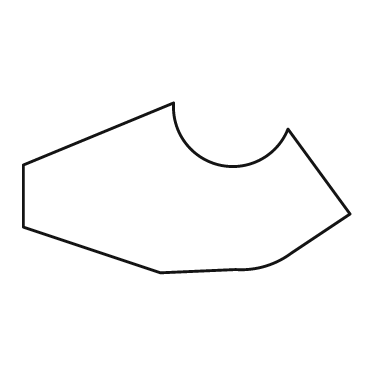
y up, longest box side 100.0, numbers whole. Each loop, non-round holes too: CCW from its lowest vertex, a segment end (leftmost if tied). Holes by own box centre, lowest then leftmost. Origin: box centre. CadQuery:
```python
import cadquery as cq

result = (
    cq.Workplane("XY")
    .moveTo(-8.0, -26.0)
    .lineTo(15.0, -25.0)
    .threePointArc((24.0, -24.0), (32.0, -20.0))
    .lineTo(50.0, -8.0)
    .lineTo(31.0, 18.0)
    .threePointArc((10.0, 7.0), (-4.0, 26.0))
    .lineTo(-50.0, 7.0)
    .lineTo(-50.0, -12.0)
    .close()
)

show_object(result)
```